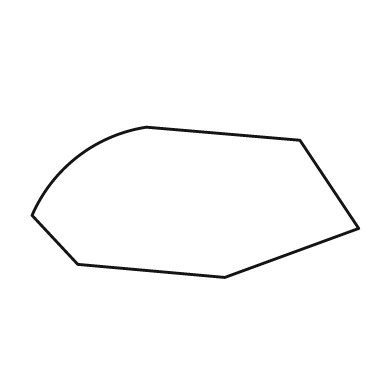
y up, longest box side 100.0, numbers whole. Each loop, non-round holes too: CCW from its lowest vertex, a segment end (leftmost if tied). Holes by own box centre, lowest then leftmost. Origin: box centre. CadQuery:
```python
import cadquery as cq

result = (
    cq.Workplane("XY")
    .moveTo(9.0, -23.0)
    .lineTo(50.0, -8.0)
    .lineTo(32.0, 19.0)
    .lineTo(-15.0, 23.0)
    .threePointArc((-36.0, 14.0), (-50.0, -4.0))
    .lineTo(-36.0, -19.0)
    .close()
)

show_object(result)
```